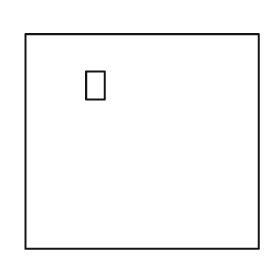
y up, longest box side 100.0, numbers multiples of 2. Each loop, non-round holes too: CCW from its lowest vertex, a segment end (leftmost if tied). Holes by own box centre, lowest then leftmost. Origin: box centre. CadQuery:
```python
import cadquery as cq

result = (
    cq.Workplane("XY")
    .moveTo(-50.0, -46.0)
    .lineTo(50.0, -46.0)
    .lineTo(50.0, 46.0)
    .lineTo(-50.0, 46.0)
    .close()
    .moveTo(-24.0, 18.0)
    .lineTo(-16.0, 18.0)
    .lineTo(-16.0, 30.0)
    .lineTo(-24.0, 30.0)
    .close()
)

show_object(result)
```